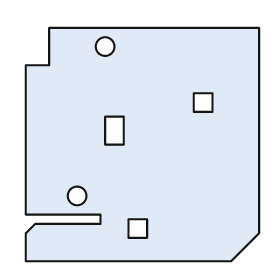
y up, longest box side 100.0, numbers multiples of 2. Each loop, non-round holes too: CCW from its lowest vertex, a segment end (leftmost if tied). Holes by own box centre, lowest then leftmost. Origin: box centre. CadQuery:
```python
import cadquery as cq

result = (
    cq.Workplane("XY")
    .moveTo(-50.0, -50.0)
    .lineTo(38.0, -50.0)
    .lineTo(50.0, -38.0)
    .lineTo(50.0, 50.0)
    .lineTo(-40.0, 50.0)
    .lineTo(-40.0, 34.0)
    .lineTo(-50.0, 34.0)
    .lineTo(-50.0, -30.0)
    .lineTo(-18.0, -30.0)
    .lineTo(-18.0, -34.0)
    .lineTo(-46.0, -34.0)
    .lineTo(-50.0, -38.0)
    .close()
    .moveTo(-6.0, -40.0)
    .lineTo(2.0, -40.0)
    .lineTo(2.0, -32.0)
    .lineTo(-6.0, -32.0)
    .close()
    .moveTo(-28.0, -22.0)
    .circle(4.0)
    .moveTo(-16.0, 0.0)
    .lineTo(-8.0, 0.0)
    .lineTo(-8.0, 12.0)
    .lineTo(-16.0, 12.0)
    .close()
    .moveTo(22.0, 14.0)
    .lineTo(30.0, 14.0)
    .lineTo(30.0, 22.0)
    .lineTo(22.0, 22.0)
    .close()
    .moveTo(-16.0, 42.0)
    .circle(4.0)
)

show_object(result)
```